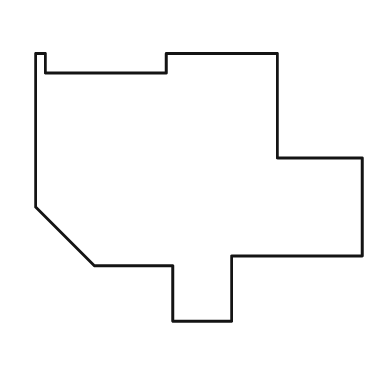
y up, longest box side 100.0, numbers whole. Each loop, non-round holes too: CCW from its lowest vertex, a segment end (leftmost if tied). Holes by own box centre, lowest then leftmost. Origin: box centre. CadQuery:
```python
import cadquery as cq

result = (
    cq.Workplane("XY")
    .moveTo(-8.0, -41.0)
    .lineTo(10.0, -41.0)
    .lineTo(10.0, -21.0)
    .lineTo(50.0, -21.0)
    .lineTo(50.0, 9.0)
    .lineTo(24.0, 9.0)
    .lineTo(24.0, 41.0)
    .lineTo(-10.0, 41.0)
    .lineTo(-10.0, 35.0)
    .lineTo(-47.0, 35.0)
    .lineTo(-47.0, 41.0)
    .lineTo(-50.0, 41.0)
    .lineTo(-50.0, -6.0)
    .lineTo(-32.0, -24.0)
    .lineTo(-8.0, -24.0)
    .close()
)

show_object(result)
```